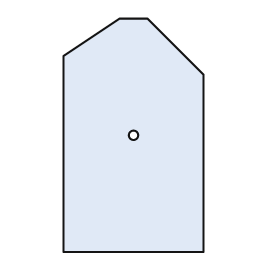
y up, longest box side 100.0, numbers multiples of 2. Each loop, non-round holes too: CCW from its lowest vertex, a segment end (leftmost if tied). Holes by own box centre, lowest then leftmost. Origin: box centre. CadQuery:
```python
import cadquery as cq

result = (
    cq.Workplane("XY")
    .moveTo(-30.0, -50.0)
    .lineTo(30.0, -50.0)
    .lineTo(30.0, 26.0)
    .lineTo(6.0, 50.0)
    .lineTo(-6.0, 50.0)
    .lineTo(-30.0, 34.0)
    .close()
    .moveTo(0.0, 0.0)
    .circle(2.0)
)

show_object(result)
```